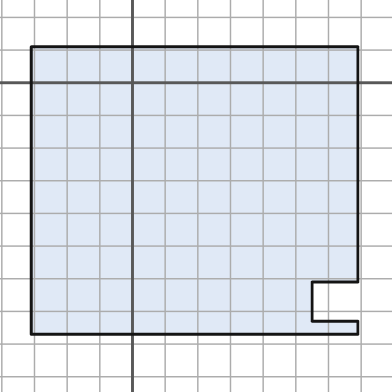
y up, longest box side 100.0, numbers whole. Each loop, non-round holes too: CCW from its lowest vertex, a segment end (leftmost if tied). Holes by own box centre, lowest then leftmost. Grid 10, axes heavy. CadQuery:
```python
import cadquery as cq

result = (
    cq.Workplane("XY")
    .moveTo(-31.0, -77.0)
    .lineTo(69.0, -77.0)
    .lineTo(69.0, -73.0)
    .lineTo(55.0, -73.0)
    .lineTo(55.0, -61.0)
    .lineTo(69.0, -61.0)
    .lineTo(69.0, 11.0)
    .lineTo(-31.0, 11.0)
    .close()
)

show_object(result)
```